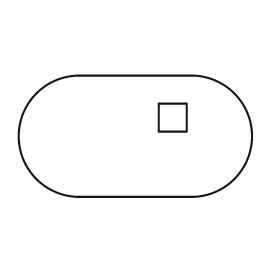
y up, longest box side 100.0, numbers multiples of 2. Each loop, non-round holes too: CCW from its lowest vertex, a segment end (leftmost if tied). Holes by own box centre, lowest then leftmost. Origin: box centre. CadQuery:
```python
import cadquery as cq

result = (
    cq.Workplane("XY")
    .moveTo(-24.0, -26.0)
    .lineTo(24.0, -26.0)
    .threePointArc((50.0, 0.0), (24.0, 26.0))
    .lineTo(-24.0, 26.0)
    .threePointArc((-50.0, 0.0), (-24.0, -26.0))
    .close()
    .moveTo(10.0, 2.0)
    .lineTo(22.0, 2.0)
    .lineTo(22.0, 14.0)
    .lineTo(10.0, 14.0)
    .close()
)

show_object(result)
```